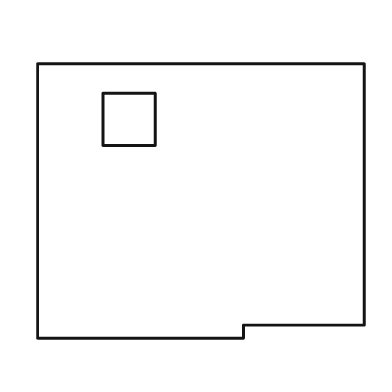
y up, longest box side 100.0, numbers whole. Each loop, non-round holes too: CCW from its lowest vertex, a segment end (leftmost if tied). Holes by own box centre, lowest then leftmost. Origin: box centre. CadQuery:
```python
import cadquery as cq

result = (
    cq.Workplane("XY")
    .moveTo(-50.0, -42.0)
    .lineTo(13.0, -42.0)
    .lineTo(13.0, -38.0)
    .lineTo(50.0, -38.0)
    .lineTo(50.0, 42.0)
    .lineTo(-50.0, 42.0)
    .close()
    .moveTo(-30.0, 17.0)
    .lineTo(-14.0, 17.0)
    .lineTo(-14.0, 33.0)
    .lineTo(-30.0, 33.0)
    .close()
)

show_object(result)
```